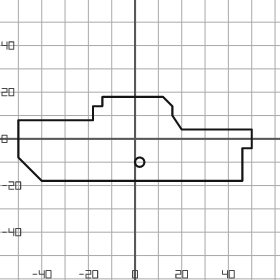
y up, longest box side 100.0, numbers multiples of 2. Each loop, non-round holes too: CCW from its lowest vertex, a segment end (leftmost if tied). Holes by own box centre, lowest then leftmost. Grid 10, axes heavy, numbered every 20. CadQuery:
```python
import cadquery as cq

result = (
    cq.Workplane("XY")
    .moveTo(-40.0, -18.0)
    .lineTo(46.0, -18.0)
    .lineTo(46.0, -4.0)
    .lineTo(50.0, -4.0)
    .lineTo(50.0, 4.0)
    .lineTo(20.0, 4.0)
    .lineTo(16.0, 10.0)
    .lineTo(16.0, 14.0)
    .lineTo(12.0, 18.0)
    .lineTo(-14.0, 18.0)
    .lineTo(-14.0, 14.0)
    .lineTo(-18.0, 14.0)
    .lineTo(-18.0, 8.0)
    .lineTo(-50.0, 8.0)
    .lineTo(-50.0, -8.0)
    .close()
    .moveTo(2.0, -10.0)
    .circle(2.0)
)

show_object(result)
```